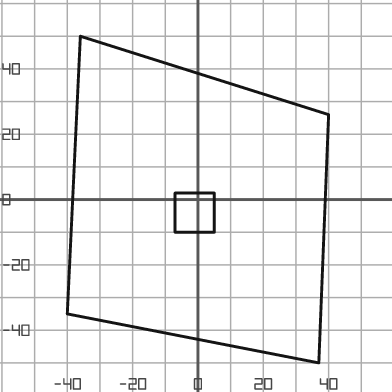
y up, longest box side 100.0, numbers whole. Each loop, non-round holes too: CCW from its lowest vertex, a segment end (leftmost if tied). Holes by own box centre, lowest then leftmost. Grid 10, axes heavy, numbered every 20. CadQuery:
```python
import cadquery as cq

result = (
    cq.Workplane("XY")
    .moveTo(37.0, -50.0)
    .lineTo(40.0, 26.0)
    .lineTo(-36.0, 50.0)
    .lineTo(-40.0, -35.0)
    .close()
    .moveTo(-7.0, -10.0)
    .lineTo(5.0, -10.0)
    .lineTo(5.0, 2.0)
    .lineTo(-7.0, 2.0)
    .close()
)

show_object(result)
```